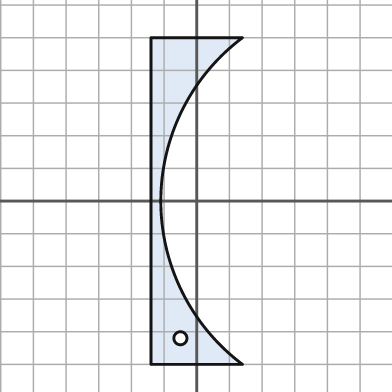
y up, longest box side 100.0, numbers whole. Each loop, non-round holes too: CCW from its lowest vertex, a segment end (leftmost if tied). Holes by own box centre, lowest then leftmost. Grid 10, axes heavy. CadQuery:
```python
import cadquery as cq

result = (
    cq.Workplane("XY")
    .moveTo(-14.0, -50.0)
    .lineTo(14.0, -50.0)
    .threePointArc((-11.0, 0.0), (14.0, 50.0))
    .lineTo(-14.0, 50.0)
    .close()
    .moveTo(-5.0, -42.0)
    .circle(2.0)
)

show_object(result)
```